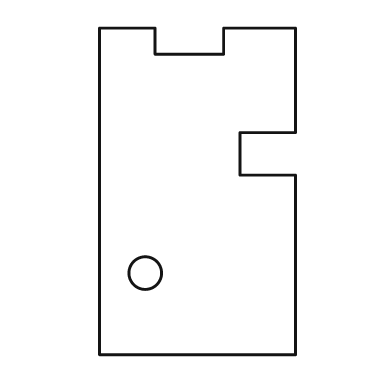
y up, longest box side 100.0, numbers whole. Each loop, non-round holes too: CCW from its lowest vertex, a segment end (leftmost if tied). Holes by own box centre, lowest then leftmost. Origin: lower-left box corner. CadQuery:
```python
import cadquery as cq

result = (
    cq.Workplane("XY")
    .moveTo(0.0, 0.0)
    .lineTo(60.0, 0.0)
    .lineTo(60.0, 55.0)
    .lineTo(43.0, 55.0)
    .lineTo(43.0, 68.0)
    .lineTo(60.0, 68.0)
    .lineTo(60.0, 100.0)
    .lineTo(38.0, 100.0)
    .lineTo(38.0, 92.0)
    .lineTo(17.0, 92.0)
    .lineTo(17.0, 100.0)
    .lineTo(0.0, 100.0)
    .close()
    .moveTo(14.0, 25.0)
    .circle(5.0)
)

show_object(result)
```